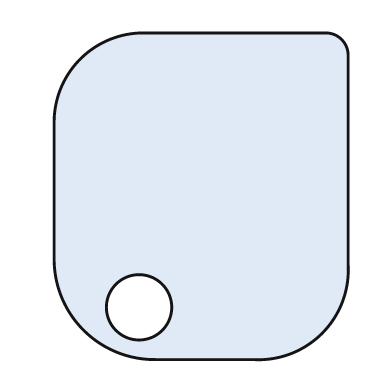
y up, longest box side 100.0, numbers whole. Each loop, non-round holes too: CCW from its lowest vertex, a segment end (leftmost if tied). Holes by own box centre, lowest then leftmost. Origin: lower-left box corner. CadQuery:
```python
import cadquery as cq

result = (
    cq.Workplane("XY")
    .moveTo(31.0, 0.0)
    .lineTo(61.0, 0.0)
    .threePointArc((82.0, 8.0), (90.0, 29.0))
    .lineTo(90.0, 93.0)
    .threePointArc((88.0, 98.0), (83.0, 100.0))
    .lineTo(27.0, 100.0)
    .threePointArc((8.0, 92.0), (0.0, 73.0))
    .lineTo(0.0, 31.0)
    .threePointArc((9.0, 9.0), (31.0, 0.0))
    .close()
    .moveTo(26.0, 16.0)
    .circle(10.0)
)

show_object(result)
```